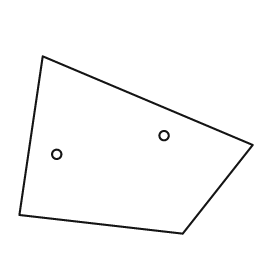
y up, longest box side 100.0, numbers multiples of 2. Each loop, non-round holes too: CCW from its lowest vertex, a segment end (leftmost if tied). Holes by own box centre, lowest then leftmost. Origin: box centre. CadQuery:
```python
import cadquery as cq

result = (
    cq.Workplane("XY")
    .moveTo(20.0, -38.0)
    .lineTo(50.0, 0.0)
    .lineTo(-40.0, 38.0)
    .lineTo(-50.0, -30.0)
    .close()
    .moveTo(-34.0, -4.0)
    .circle(2.0)
    .moveTo(12.0, 4.0)
    .circle(2.0)
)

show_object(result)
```